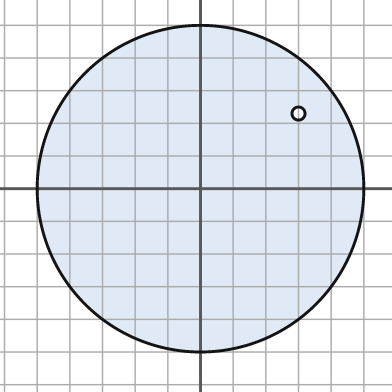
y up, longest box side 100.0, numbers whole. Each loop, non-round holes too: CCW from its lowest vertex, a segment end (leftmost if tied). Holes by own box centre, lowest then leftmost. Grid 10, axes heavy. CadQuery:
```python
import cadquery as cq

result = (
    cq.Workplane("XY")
    .moveTo(0.0, 0.0)
    .circle(50.0)
    .moveTo(30.0, 23.0)
    .circle(2.0)
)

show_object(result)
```